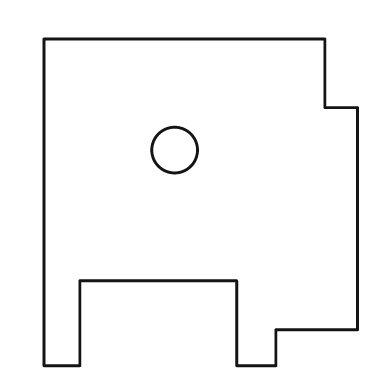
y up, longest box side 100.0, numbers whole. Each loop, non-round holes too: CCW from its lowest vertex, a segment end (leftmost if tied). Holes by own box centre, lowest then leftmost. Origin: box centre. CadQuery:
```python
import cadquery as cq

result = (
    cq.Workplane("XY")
    .moveTo(-48.0, -50.0)
    .lineTo(-37.0, -50.0)
    .lineTo(-37.0, -24.0)
    .lineTo(11.0, -24.0)
    .lineTo(11.0, -50.0)
    .lineTo(23.0, -50.0)
    .lineTo(23.0, -39.0)
    .lineTo(48.0, -39.0)
    .lineTo(48.0, 29.0)
    .lineTo(38.0, 29.0)
    .lineTo(38.0, 50.0)
    .lineTo(-48.0, 50.0)
    .close()
    .moveTo(-8.0, 16.0)
    .circle(7.0)
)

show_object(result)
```